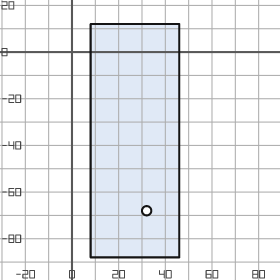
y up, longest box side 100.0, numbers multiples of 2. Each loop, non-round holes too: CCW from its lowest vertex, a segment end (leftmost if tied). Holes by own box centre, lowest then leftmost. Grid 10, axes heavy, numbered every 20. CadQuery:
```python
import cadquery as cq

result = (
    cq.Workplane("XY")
    .moveTo(8.0, -88.0)
    .lineTo(46.0, -88.0)
    .lineTo(46.0, 12.0)
    .lineTo(8.0, 12.0)
    .close()
    .moveTo(32.0, -68.0)
    .circle(2.0)
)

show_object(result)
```